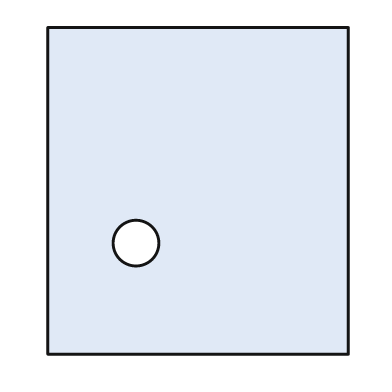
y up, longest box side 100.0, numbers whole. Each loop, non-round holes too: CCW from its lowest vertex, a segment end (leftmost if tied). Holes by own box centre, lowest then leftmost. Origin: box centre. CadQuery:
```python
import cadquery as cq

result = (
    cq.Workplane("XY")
    .moveTo(-46.0, -50.0)
    .lineTo(46.0, -50.0)
    .lineTo(46.0, 50.0)
    .lineTo(-46.0, 50.0)
    .close()
    .moveTo(-19.0, -16.0)
    .circle(7.0)
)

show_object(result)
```